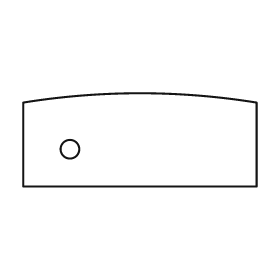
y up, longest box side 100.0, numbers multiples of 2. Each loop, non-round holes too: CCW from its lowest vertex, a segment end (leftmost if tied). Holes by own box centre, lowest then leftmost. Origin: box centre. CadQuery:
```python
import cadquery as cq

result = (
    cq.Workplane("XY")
    .moveTo(-50.0, -20.0)
    .lineTo(50.0, -20.0)
    .lineTo(50.0, 16.0)
    .threePointArc((0.0, 20.0), (-50.0, 16.0))
    .close()
    .moveTo(-30.0, -4.0)
    .circle(4.0)
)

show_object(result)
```